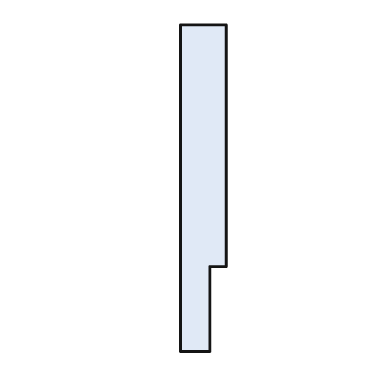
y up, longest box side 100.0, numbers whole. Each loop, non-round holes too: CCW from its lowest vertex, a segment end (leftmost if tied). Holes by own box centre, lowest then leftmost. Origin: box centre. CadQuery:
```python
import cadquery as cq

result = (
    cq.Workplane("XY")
    .moveTo(-7.0, -50.0)
    .lineTo(2.0, -50.0)
    .lineTo(2.0, -24.0)
    .lineTo(7.0, -24.0)
    .lineTo(7.0, 50.0)
    .lineTo(-7.0, 50.0)
    .close()
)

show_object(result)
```